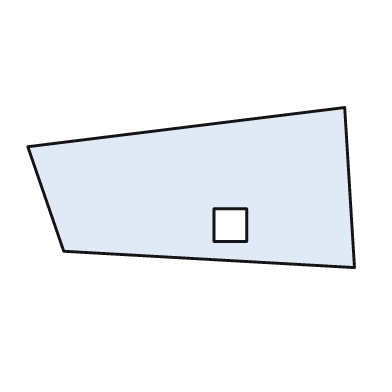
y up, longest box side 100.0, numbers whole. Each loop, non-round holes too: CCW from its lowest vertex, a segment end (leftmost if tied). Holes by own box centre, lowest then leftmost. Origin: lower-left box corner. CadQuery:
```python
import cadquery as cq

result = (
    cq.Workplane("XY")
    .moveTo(100.0, 0.0)
    .lineTo(97.0, 49.0)
    .lineTo(0.0, 37.0)
    .lineTo(11.0, 5.0)
    .close()
    .moveTo(57.0, 8.0)
    .lineTo(67.0, 8.0)
    .lineTo(67.0, 18.0)
    .lineTo(57.0, 18.0)
    .close()
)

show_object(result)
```